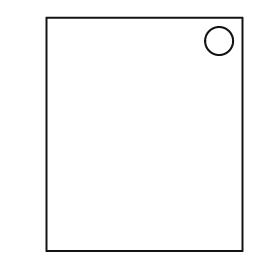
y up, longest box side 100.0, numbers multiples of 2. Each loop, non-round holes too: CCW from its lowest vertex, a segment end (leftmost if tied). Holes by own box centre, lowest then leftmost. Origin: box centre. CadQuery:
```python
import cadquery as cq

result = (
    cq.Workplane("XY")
    .moveTo(-42.0, -50.0)
    .lineTo(42.0, -50.0)
    .lineTo(42.0, 50.0)
    .lineTo(-42.0, 50.0)
    .close()
    .moveTo(32.0, 40.0)
    .circle(6.0)
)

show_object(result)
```